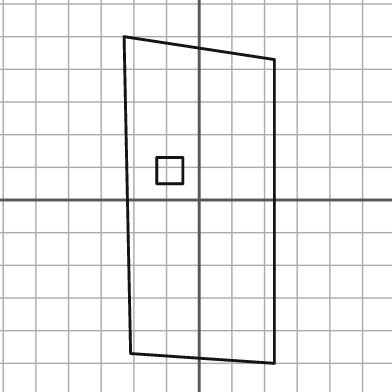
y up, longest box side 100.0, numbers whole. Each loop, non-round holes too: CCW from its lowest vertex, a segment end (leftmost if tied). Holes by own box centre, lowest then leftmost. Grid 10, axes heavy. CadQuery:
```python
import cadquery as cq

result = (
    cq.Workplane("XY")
    .moveTo(23.0, -50.0)
    .lineTo(23.0, 43.0)
    .lineTo(-23.0, 50.0)
    .lineTo(-21.0, -47.0)
    .close()
    .moveTo(-13.0, 5.0)
    .lineTo(-5.0, 5.0)
    .lineTo(-5.0, 13.0)
    .lineTo(-13.0, 13.0)
    .close()
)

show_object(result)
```